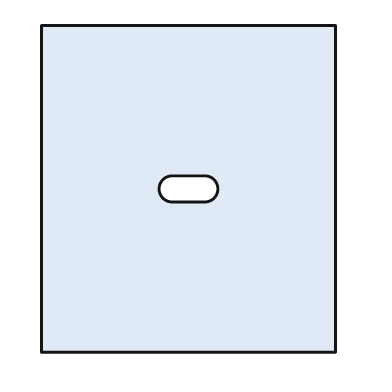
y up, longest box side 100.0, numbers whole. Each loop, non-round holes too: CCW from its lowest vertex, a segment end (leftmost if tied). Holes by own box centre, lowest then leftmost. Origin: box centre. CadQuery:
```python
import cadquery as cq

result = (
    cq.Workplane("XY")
    .moveTo(-45.0, -50.0)
    .lineTo(45.0, -50.0)
    .lineTo(45.0, 50.0)
    .lineTo(-45.0, 50.0)
    .close()
    .moveTo(-5.0, -4.0)
    .lineTo(5.0, -4.0)
    .threePointArc((9.0, 0.0), (5.0, 4.0))
    .lineTo(-5.0, 4.0)
    .threePointArc((-9.0, 0.0), (-5.0, -4.0))
    .close()
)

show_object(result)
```